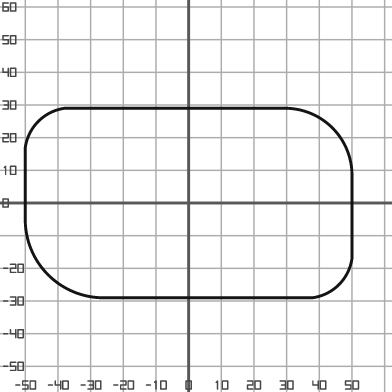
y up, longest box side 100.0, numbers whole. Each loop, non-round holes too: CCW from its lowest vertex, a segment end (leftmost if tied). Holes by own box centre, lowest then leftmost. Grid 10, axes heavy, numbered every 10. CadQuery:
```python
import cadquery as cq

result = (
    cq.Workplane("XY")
    .moveTo(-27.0, -29.0)
    .lineTo(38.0, -29.0)
    .threePointArc((46.0, -25.0), (50.0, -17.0))
    .lineTo(50.0, 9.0)
    .threePointArc((44.0, 23.0), (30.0, 29.0))
    .lineTo(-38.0, 29.0)
    .threePointArc((-46.0, 25.0), (-50.0, 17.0))
    .lineTo(-50.0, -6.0)
    .threePointArc((-43.0, -22.0), (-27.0, -29.0))
    .close()
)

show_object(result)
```